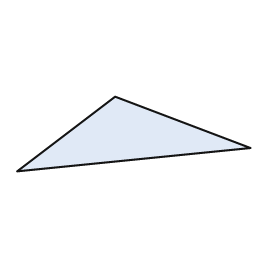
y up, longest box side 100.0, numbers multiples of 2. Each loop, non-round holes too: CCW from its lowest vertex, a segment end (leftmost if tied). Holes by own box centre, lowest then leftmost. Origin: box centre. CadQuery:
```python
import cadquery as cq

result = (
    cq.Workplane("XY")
    .moveTo(-50.0, -16.0)
    .lineTo(50.0, -6.0)
    .lineTo(-8.0, 16.0)
    .close()
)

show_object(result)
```